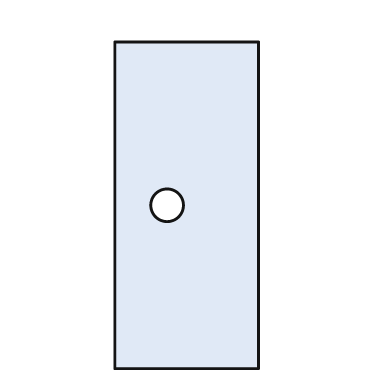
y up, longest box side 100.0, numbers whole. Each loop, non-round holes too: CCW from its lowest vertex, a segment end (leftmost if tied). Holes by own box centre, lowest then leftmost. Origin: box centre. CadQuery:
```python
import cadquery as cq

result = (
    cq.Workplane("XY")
    .moveTo(-22.0, -50.0)
    .lineTo(22.0, -50.0)
    .lineTo(22.0, 50.0)
    .lineTo(-22.0, 50.0)
    .close()
    .moveTo(-6.0, 0.0)
    .circle(5.0)
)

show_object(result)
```